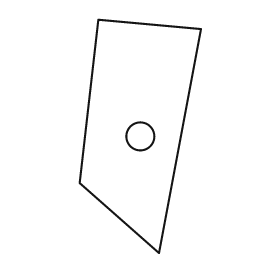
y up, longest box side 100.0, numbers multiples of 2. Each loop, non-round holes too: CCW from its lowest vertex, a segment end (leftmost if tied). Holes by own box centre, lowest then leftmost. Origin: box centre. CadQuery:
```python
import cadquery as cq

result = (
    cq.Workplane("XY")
    .moveTo(8.0, -50.0)
    .lineTo(26.0, 46.0)
    .lineTo(-18.0, 50.0)
    .lineTo(-26.0, -20.0)
    .close()
    .moveTo(0.0, 0.0)
    .circle(6.0)
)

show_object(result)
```